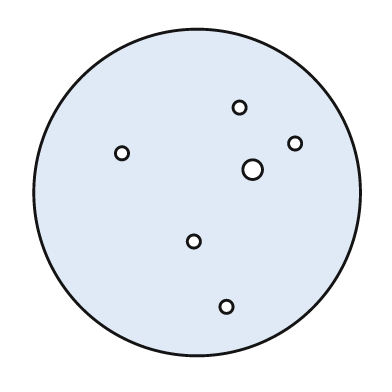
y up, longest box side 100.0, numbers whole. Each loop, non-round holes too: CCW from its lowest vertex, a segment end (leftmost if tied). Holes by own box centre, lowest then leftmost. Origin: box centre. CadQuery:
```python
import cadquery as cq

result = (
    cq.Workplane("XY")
    .moveTo(0.0, 0.0)
    .circle(50.0)
    .moveTo(9.0, -35.0)
    .circle(2.0)
    .moveTo(-1.0, -15.0)
    .circle(2.0)
    .moveTo(17.0, 7.0)
    .circle(3.0)
    .moveTo(-23.0, 12.0)
    .circle(2.0)
    .moveTo(30.0, 15.0)
    .circle(2.0)
    .moveTo(13.0, 26.0)
    .circle(2.0)
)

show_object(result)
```